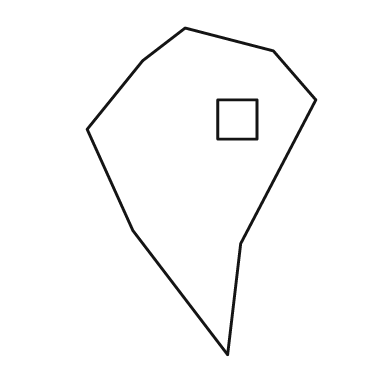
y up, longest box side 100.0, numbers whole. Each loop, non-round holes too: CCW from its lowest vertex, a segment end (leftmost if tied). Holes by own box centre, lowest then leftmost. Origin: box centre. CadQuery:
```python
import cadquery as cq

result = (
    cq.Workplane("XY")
    .moveTo(8.0, -50.0)
    .lineTo(12.0, -16.0)
    .lineTo(35.0, 28.0)
    .lineTo(22.0, 43.0)
    .lineTo(-5.0, 50.0)
    .lineTo(-18.0, 40.0)
    .lineTo(-35.0, 19.0)
    .lineTo(-21.0, -12.0)
    .close()
    .moveTo(5.0, 16.0)
    .lineTo(17.0, 16.0)
    .lineTo(17.0, 28.0)
    .lineTo(5.0, 28.0)
    .close()
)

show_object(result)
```